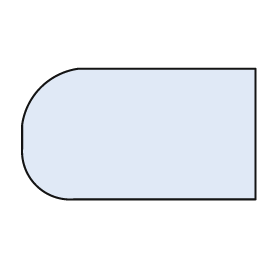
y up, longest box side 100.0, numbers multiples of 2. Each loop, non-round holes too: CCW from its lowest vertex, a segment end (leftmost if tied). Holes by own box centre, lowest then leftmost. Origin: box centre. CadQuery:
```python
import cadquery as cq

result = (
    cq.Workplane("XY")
    .moveTo(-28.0, -28.0)
    .lineTo(50.0, -28.0)
    .lineTo(50.0, 28.0)
    .lineTo(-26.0, 28.0)
    .threePointArc((-42.0, 20.0), (-50.0, 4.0))
    .lineTo(-50.0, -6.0)
    .threePointArc((-44.0, -22.0), (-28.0, -28.0))
    .close()
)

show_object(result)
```